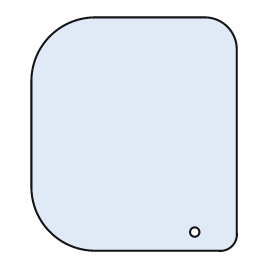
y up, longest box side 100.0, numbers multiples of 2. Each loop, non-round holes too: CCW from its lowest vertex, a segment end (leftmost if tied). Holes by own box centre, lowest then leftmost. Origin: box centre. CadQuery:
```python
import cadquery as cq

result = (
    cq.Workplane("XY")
    .moveTo(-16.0, -50.0)
    .lineTo(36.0, -50.0)
    .threePointArc((42.0, -48.0), (44.0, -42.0))
    .lineTo(44.0, 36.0)
    .threePointArc((40.0, 46.0), (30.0, 50.0))
    .lineTo(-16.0, 50.0)
    .threePointArc((-36.0, 42.0), (-44.0, 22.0))
    .lineTo(-44.0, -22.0)
    .threePointArc((-36.0, -42.0), (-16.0, -50.0))
    .close()
    .moveTo(26.0, -42.0)
    .circle(2.0)
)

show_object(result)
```